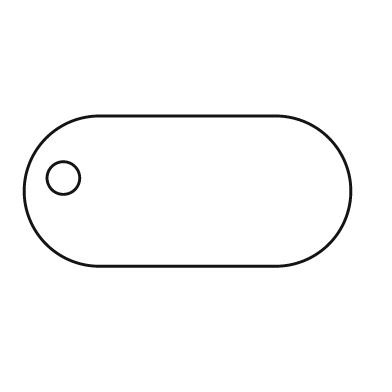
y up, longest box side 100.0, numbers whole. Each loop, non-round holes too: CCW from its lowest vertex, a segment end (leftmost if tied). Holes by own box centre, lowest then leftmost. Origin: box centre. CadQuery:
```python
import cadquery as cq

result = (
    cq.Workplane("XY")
    .moveTo(-27.0, -23.0)
    .lineTo(27.0, -23.0)
    .threePointArc((50.0, 0.0), (27.0, 23.0))
    .lineTo(-27.0, 23.0)
    .threePointArc((-50.0, 0.0), (-27.0, -23.0))
    .close()
    .moveTo(-38.0, 4.0)
    .circle(5.0)
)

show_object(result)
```